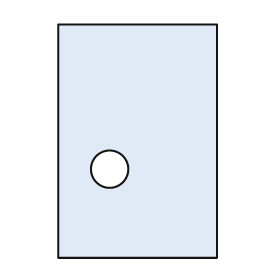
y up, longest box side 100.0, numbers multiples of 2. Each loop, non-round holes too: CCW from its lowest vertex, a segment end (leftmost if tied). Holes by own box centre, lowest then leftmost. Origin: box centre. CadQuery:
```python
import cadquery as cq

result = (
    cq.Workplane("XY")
    .moveTo(-34.0, -50.0)
    .lineTo(34.0, -50.0)
    .lineTo(34.0, 50.0)
    .lineTo(-34.0, 50.0)
    .close()
    .moveTo(-12.0, -12.0)
    .circle(8.0)
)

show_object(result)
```